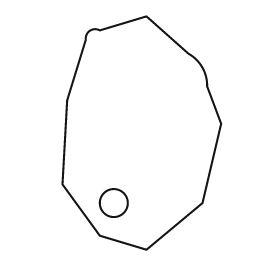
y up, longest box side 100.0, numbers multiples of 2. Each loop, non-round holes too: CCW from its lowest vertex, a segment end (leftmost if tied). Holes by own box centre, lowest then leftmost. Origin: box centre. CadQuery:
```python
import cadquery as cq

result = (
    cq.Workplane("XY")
    .moveTo(2.0, -50.0)
    .lineTo(26.0, -30.0)
    .lineTo(34.0, 4.0)
    .lineTo(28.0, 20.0)
    .threePointArc((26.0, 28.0), (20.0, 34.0))
    .lineTo(2.0, 50.0)
    .lineTo(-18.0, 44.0)
    .threePointArc((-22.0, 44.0), (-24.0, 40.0))
    .lineTo(-32.0, 14.0)
    .lineTo(-34.0, -22.0)
    .lineTo(-18.0, -44.0)
    .close()
    .moveTo(-12.0, -30.0)
    .circle(6.0)
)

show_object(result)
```